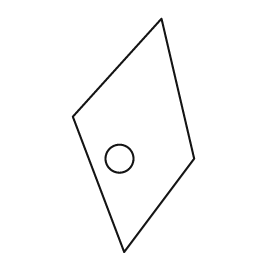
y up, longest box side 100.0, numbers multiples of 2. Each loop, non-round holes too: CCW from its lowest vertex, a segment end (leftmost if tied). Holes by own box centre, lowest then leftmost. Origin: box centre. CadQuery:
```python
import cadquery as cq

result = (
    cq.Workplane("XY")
    .moveTo(-4.0, -50.0)
    .lineTo(26.0, -10.0)
    .lineTo(12.0, 50.0)
    .lineTo(-26.0, 8.0)
    .close()
    .moveTo(-6.0, -10.0)
    .circle(6.0)
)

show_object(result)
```